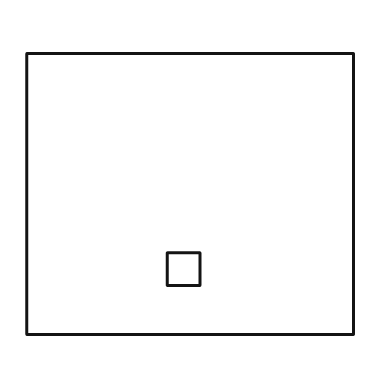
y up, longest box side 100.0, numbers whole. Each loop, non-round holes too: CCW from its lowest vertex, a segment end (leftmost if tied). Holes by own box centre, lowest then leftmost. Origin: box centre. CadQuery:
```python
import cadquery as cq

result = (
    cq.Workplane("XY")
    .moveTo(-50.0, -43.0)
    .lineTo(50.0, -43.0)
    .lineTo(50.0, 43.0)
    .lineTo(-50.0, 43.0)
    .close()
    .moveTo(-7.0, -28.0)
    .lineTo(3.0, -28.0)
    .lineTo(3.0, -18.0)
    .lineTo(-7.0, -18.0)
    .close()
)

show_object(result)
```